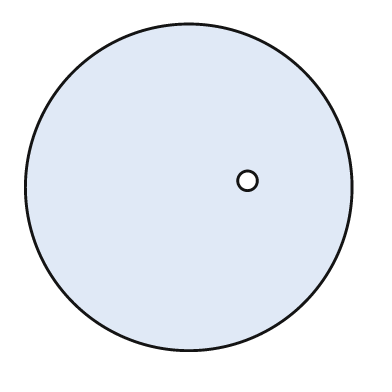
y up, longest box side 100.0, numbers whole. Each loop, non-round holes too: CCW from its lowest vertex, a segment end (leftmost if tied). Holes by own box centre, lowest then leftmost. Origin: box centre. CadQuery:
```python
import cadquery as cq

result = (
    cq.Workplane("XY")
    .moveTo(0.0, 0.0)
    .circle(50.0)
    .moveTo(18.0, 2.0)
    .circle(3.0)
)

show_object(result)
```